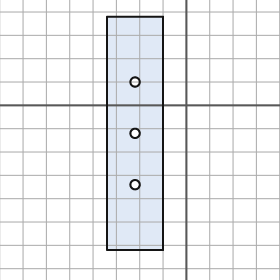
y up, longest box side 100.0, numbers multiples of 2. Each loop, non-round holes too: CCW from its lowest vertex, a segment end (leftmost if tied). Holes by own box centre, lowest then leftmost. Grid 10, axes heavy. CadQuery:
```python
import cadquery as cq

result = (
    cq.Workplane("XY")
    .moveTo(-34.0, -62.0)
    .lineTo(-10.0, -62.0)
    .lineTo(-10.0, 38.0)
    .lineTo(-34.0, 38.0)
    .close()
    .moveTo(-22.0, -34.0)
    .circle(2.0)
    .moveTo(-22.0, -12.0)
    .circle(2.0)
    .moveTo(-22.0, 10.0)
    .circle(2.0)
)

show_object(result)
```